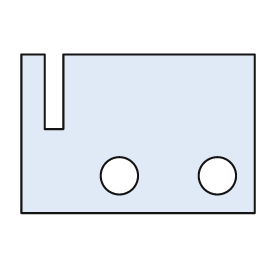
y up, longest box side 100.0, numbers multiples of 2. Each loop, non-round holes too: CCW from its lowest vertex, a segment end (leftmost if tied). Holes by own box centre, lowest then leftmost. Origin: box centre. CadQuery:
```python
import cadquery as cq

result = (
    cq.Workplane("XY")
    .moveTo(-50.0, -34.0)
    .lineTo(50.0, -34.0)
    .lineTo(50.0, 34.0)
    .lineTo(-32.0, 34.0)
    .lineTo(-32.0, 2.0)
    .lineTo(-40.0, 2.0)
    .lineTo(-40.0, 34.0)
    .lineTo(-50.0, 34.0)
    .close()
    .moveTo(-8.0, -18.0)
    .circle(8.0)
    .moveTo(34.0, -18.0)
    .circle(8.0)
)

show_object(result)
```